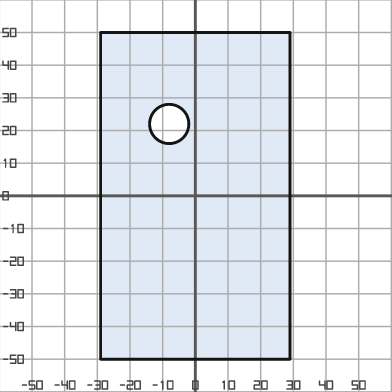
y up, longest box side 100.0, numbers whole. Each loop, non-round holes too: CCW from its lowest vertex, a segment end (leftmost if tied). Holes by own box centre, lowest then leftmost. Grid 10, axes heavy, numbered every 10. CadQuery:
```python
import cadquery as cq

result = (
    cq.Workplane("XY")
    .moveTo(-29.0, -50.0)
    .lineTo(29.0, -50.0)
    .lineTo(29.0, 50.0)
    .lineTo(-29.0, 50.0)
    .close()
    .moveTo(-8.0, 22.0)
    .circle(6.0)
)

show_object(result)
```